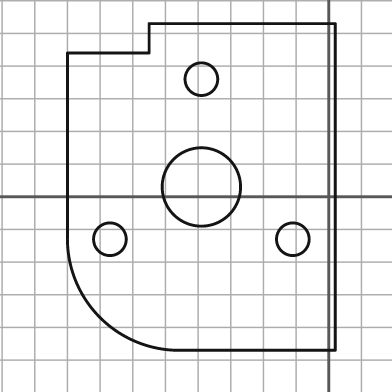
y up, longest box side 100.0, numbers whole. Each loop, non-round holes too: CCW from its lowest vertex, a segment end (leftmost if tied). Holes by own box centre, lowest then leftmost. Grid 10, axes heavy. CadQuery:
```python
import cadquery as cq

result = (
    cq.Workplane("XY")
    .moveTo(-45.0, -47.0)
    .lineTo(2.0, -47.0)
    .lineTo(2.0, 53.0)
    .lineTo(-55.0, 53.0)
    .lineTo(-55.0, 44.0)
    .lineTo(-80.0, 44.0)
    .lineTo(-80.0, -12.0)
    .threePointArc((-70.0, -37.0), (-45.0, -47.0))
    .close()
    .moveTo(-67.0, -13.0)
    .circle(5.0)
    .moveTo(-11.0, -13.0)
    .circle(5.0)
    .moveTo(-39.0, 3.0)
    .circle(12.0)
    .moveTo(-39.0, 36.0)
    .circle(5.0)
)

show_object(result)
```